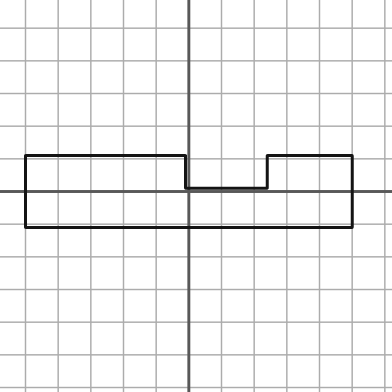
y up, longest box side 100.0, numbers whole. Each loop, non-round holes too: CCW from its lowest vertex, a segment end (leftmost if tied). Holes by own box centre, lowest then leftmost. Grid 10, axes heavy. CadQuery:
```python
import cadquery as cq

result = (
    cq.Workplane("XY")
    .moveTo(-50.0, -11.0)
    .lineTo(50.0, -11.0)
    .lineTo(50.0, 11.0)
    .lineTo(24.0, 11.0)
    .lineTo(24.0, 1.0)
    .lineTo(-1.0, 1.0)
    .lineTo(-1.0, 11.0)
    .lineTo(-50.0, 11.0)
    .close()
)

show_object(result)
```